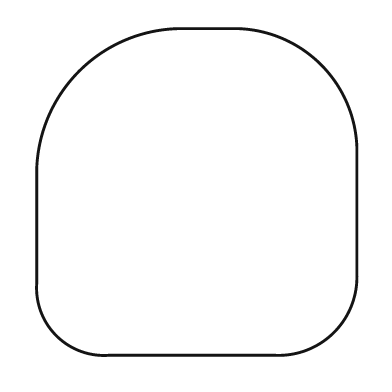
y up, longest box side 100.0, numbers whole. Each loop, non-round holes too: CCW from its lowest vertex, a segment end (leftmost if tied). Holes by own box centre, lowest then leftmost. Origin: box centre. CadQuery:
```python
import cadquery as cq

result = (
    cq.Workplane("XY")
    .moveTo(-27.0, -50.0)
    .lineTo(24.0, -50.0)
    .threePointArc((42.0, -43.0), (49.0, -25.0))
    .lineTo(49.0, 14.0)
    .threePointArc((38.0, 39.0), (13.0, 50.0))
    .lineTo(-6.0, 50.0)
    .threePointArc((-36.0, 37.0), (-49.0, 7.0))
    .lineTo(-49.0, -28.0)
    .threePointArc((-43.0, -44.0), (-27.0, -50.0))
    .close()
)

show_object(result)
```